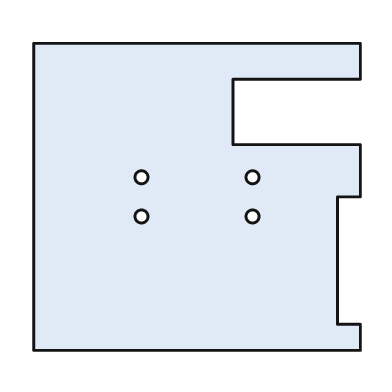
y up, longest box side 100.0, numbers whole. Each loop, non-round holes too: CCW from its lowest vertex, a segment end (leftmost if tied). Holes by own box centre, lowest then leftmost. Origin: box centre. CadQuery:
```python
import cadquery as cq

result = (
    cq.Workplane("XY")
    .moveTo(-50.0, -47.0)
    .lineTo(50.0, -47.0)
    .lineTo(50.0, -39.0)
    .lineTo(43.0, -39.0)
    .lineTo(43.0, 0.0)
    .lineTo(50.0, 0.0)
    .lineTo(50.0, 16.0)
    .lineTo(11.0, 16.0)
    .lineTo(11.0, 36.0)
    .lineTo(50.0, 36.0)
    .lineTo(50.0, 47.0)
    .lineTo(-50.0, 47.0)
    .close()
    .moveTo(-17.0, -6.0)
    .circle(2.0)
    .moveTo(17.0, -6.0)
    .circle(2.0)
    .moveTo(-17.0, 6.0)
    .circle(2.0)
    .moveTo(17.0, 6.0)
    .circle(2.0)
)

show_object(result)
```